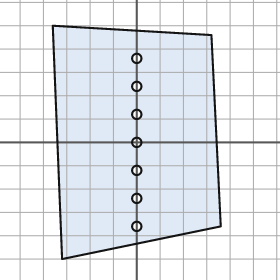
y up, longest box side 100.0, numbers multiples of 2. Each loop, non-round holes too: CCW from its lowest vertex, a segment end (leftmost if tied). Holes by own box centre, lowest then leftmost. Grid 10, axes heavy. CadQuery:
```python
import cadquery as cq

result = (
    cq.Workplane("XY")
    .moveTo(-32.0, -50.0)
    .lineTo(36.0, -36.0)
    .lineTo(32.0, 46.0)
    .lineTo(-36.0, 50.0)
    .close()
    .moveTo(0.0, -36.0)
    .circle(2.0)
    .moveTo(0.0, -24.0)
    .circle(2.0)
    .moveTo(0.0, -12.0)
    .circle(2.0)
    .moveTo(0.0, 0.0)
    .circle(2.0)
    .moveTo(0.0, 12.0)
    .circle(2.0)
    .moveTo(0.0, 24.0)
    .circle(2.0)
    .moveTo(0.0, 36.0)
    .circle(2.0)
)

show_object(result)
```